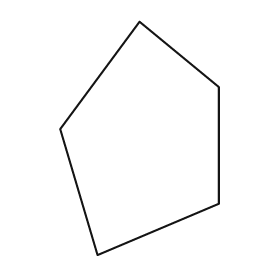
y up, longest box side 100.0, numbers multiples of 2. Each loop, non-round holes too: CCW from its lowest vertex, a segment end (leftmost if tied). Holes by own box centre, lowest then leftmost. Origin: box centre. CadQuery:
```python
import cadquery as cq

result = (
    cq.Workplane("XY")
    .moveTo(-18.0, -50.0)
    .lineTo(34.0, -28.0)
    .lineTo(34.0, 22.0)
    .lineTo(0.0, 50.0)
    .lineTo(-34.0, 4.0)
    .close()
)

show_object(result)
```